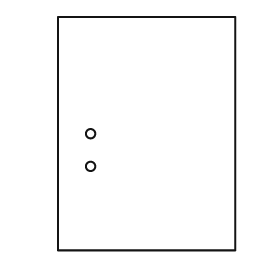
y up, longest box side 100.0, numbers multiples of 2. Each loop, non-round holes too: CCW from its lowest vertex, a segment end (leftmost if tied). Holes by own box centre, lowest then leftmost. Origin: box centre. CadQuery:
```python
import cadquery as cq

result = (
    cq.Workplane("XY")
    .moveTo(-38.0, -50.0)
    .lineTo(38.0, -50.0)
    .lineTo(38.0, 50.0)
    .lineTo(-38.0, 50.0)
    .close()
    .moveTo(-24.0, -14.0)
    .circle(2.0)
    .moveTo(-24.0, 0.0)
    .circle(2.0)
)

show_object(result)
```